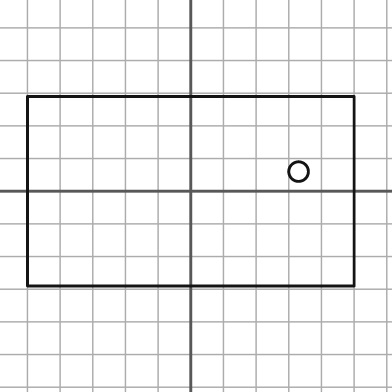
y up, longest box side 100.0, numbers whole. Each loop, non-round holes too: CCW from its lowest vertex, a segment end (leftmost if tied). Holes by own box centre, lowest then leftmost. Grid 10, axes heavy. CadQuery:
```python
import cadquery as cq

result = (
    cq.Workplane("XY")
    .moveTo(-50.0, -29.0)
    .lineTo(50.0, -29.0)
    .lineTo(50.0, 29.0)
    .lineTo(-50.0, 29.0)
    .close()
    .moveTo(33.0, 6.0)
    .circle(3.0)
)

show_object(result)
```